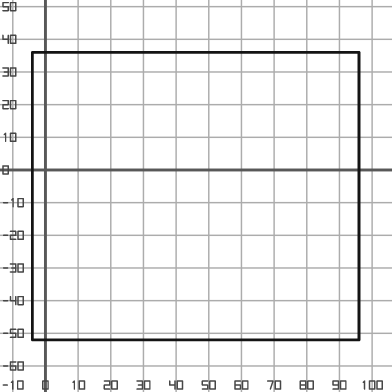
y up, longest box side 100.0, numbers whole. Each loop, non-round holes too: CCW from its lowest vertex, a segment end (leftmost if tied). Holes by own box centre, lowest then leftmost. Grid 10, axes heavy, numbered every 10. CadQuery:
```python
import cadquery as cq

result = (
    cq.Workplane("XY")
    .moveTo(-4.0, -52.0)
    .lineTo(96.0, -52.0)
    .lineTo(96.0, 36.0)
    .lineTo(-4.0, 36.0)
    .close()
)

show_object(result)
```